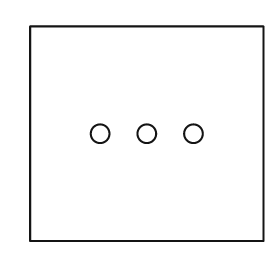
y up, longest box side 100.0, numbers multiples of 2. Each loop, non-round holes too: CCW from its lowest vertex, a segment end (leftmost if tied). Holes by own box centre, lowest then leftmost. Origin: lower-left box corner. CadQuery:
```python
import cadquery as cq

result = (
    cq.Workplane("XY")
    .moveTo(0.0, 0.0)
    .lineTo(100.0, 0.0)
    .lineTo(100.0, 92.0)
    .lineTo(0.0, 92.0)
    .close()
    .moveTo(30.0, 46.0)
    .circle(4.0)
    .moveTo(50.0, 46.0)
    .circle(4.0)
    .moveTo(70.0, 46.0)
    .circle(4.0)
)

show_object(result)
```